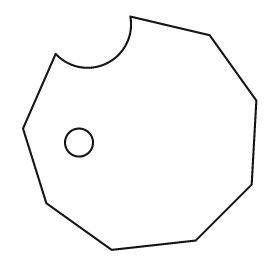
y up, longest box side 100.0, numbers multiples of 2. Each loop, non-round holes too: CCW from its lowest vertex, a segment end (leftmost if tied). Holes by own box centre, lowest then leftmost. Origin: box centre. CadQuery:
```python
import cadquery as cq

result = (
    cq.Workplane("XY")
    .moveTo(-12.0, -50.0)
    .lineTo(24.0, -46.0)
    .lineTo(48.0, -22.0)
    .lineTo(50.0, 14.0)
    .lineTo(30.0, 42.0)
    .lineTo(-4.0, 50.0)
    .threePointArc((-14.0, 30.0), (-36.0, 34.0))
    .lineTo(-50.0, 2.0)
    .lineTo(-40.0, -30.0)
    .close()
    .moveTo(-26.0, -4.0)
    .circle(6.0)
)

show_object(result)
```